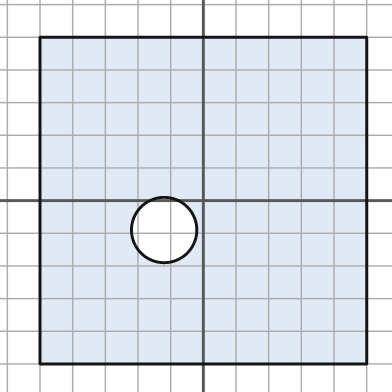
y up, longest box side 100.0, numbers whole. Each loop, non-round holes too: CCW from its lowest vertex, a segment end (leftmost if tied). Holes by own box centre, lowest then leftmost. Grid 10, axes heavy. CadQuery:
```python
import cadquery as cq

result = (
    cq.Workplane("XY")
    .moveTo(-50.0, -50.0)
    .lineTo(50.0, -50.0)
    .lineTo(50.0, 50.0)
    .lineTo(-50.0, 50.0)
    .close()
    .moveTo(-12.0, -9.0)
    .circle(10.0)
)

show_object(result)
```